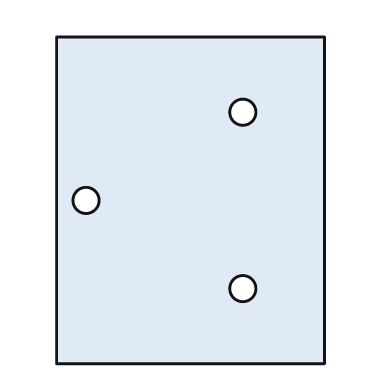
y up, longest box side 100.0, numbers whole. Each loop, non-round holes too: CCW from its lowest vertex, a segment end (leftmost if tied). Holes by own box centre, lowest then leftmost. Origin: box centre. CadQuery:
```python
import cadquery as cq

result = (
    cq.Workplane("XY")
    .moveTo(-41.0, -50.0)
    .lineTo(41.0, -50.0)
    .lineTo(41.0, 50.0)
    .lineTo(-41.0, 50.0)
    .close()
    .moveTo(16.0, -27.0)
    .circle(4.0)
    .moveTo(-32.0, 0.0)
    .circle(4.0)
    .moveTo(16.0, 27.0)
    .circle(4.0)
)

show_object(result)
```